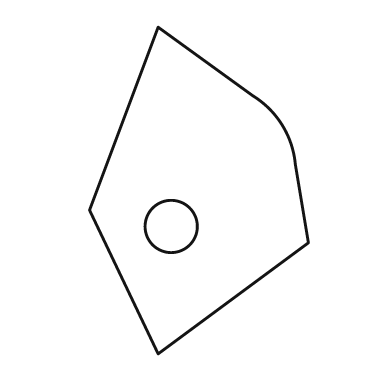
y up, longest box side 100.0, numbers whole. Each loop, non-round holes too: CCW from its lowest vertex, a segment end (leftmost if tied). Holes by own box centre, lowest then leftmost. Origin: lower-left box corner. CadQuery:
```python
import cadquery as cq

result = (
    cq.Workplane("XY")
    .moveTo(21.0, 0.0)
    .lineTo(67.0, 34.0)
    .lineTo(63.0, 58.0)
    .threePointArc((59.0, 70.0), (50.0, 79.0))
    .lineTo(21.0, 100.0)
    .lineTo(0.0, 44.0)
    .close()
    .moveTo(25.0, 39.0)
    .circle(8.0)
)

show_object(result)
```